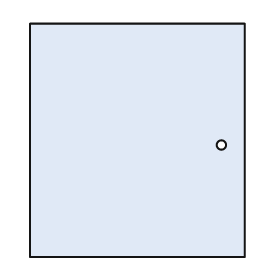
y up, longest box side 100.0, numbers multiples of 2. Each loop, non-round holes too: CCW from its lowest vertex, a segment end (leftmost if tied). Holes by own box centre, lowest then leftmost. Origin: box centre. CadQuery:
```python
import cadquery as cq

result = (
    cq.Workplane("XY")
    .moveTo(-46.0, -50.0)
    .lineTo(46.0, -50.0)
    .lineTo(46.0, 50.0)
    .lineTo(-46.0, 50.0)
    .close()
    .moveTo(36.0, -2.0)
    .circle(2.0)
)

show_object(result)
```